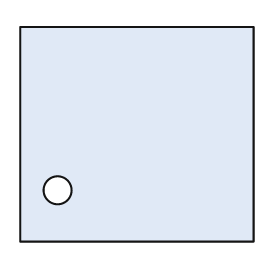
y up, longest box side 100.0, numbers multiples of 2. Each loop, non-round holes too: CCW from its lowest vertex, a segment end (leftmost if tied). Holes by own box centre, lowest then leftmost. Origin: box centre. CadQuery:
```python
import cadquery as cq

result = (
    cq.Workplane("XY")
    .moveTo(-50.0, -46.0)
    .lineTo(50.0, -46.0)
    .lineTo(50.0, 46.0)
    .lineTo(-50.0, 46.0)
    .close()
    .moveTo(-34.0, -24.0)
    .circle(6.0)
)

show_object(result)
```